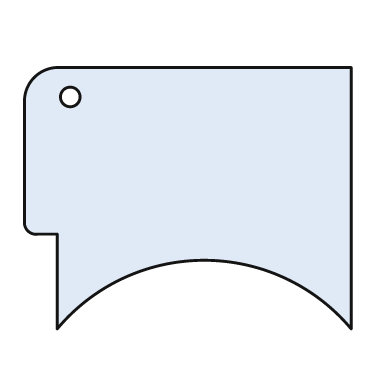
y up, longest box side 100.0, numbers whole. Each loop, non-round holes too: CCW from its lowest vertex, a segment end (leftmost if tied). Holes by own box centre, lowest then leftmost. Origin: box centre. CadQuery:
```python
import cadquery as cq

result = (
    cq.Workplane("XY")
    .moveTo(-40.0, -40.0)
    .threePointArc((5.0, -19.0), (50.0, -40.0))
    .lineTo(50.0, 40.0)
    .lineTo(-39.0, 40.0)
    .threePointArc((-47.0, 37.0), (-50.0, 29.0))
    .lineTo(-50.0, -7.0)
    .threePointArc((-49.0, -10.0), (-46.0, -11.0))
    .lineTo(-40.0, -11.0)
    .close()
    .moveTo(-36.0, 31.0)
    .circle(3.0)
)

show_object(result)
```